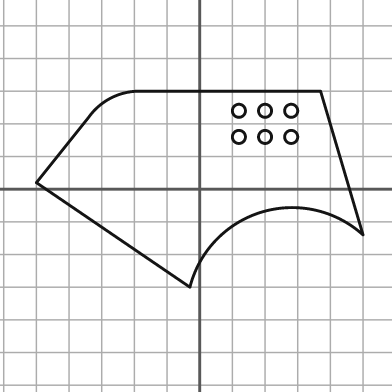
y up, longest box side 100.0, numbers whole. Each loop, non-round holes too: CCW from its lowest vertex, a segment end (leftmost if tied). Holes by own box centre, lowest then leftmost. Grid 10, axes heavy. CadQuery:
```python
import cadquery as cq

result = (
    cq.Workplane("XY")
    .moveTo(-3.0, -30.0)
    .threePointArc((19.0, -7.0), (50.0, -14.0))
    .lineTo(37.0, 30.0)
    .lineTo(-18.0, 30.0)
    .threePointArc((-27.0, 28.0), (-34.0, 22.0))
    .lineTo(-50.0, 2.0)
    .close()
    .moveTo(12.0, 16.0)
    .circle(2.0)
    .moveTo(20.0, 16.0)
    .circle(2.0)
    .moveTo(28.0, 16.0)
    .circle(2.0)
    .moveTo(12.0, 24.0)
    .circle(2.0)
    .moveTo(20.0, 24.0)
    .circle(2.0)
    .moveTo(28.0, 24.0)
    .circle(2.0)
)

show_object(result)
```